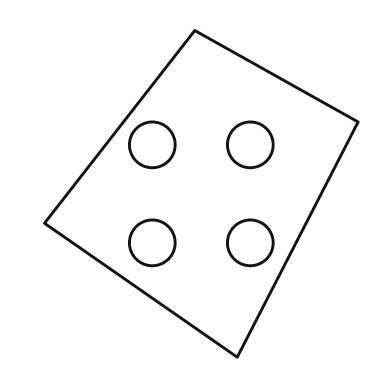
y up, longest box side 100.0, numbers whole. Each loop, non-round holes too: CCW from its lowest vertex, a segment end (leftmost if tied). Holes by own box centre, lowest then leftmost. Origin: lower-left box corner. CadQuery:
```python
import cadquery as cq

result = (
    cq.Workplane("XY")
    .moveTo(59.0, 0.0)
    .lineTo(96.0, 72.0)
    .lineTo(46.0, 100.0)
    .lineTo(0.0, 41.0)
    .close()
    .moveTo(33.0, 35.0)
    .circle(7.0)
    .moveTo(63.0, 35.0)
    .circle(7.0)
    .moveTo(33.0, 65.0)
    .circle(7.0)
    .moveTo(63.0, 65.0)
    .circle(7.0)
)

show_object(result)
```